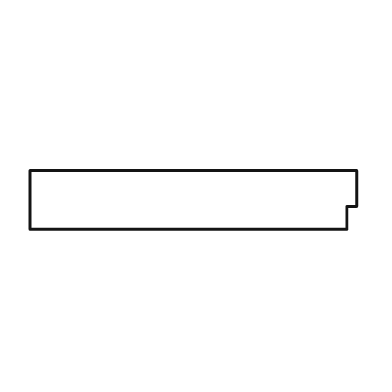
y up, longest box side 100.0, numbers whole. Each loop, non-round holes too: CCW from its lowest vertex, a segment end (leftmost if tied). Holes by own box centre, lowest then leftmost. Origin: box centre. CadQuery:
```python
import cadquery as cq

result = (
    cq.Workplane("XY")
    .moveTo(-50.0, -9.0)
    .lineTo(47.0, -9.0)
    .lineTo(47.0, -2.0)
    .lineTo(50.0, -2.0)
    .lineTo(50.0, 9.0)
    .lineTo(-50.0, 9.0)
    .close()
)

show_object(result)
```